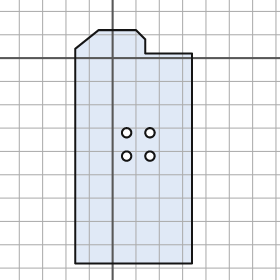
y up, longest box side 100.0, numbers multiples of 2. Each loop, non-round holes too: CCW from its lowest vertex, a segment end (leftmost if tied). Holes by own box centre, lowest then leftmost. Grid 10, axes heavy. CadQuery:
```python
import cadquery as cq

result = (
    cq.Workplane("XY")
    .moveTo(-16.0, -88.0)
    .lineTo(34.0, -88.0)
    .lineTo(34.0, 2.0)
    .lineTo(14.0, 2.0)
    .lineTo(14.0, 8.0)
    .lineTo(10.0, 12.0)
    .lineTo(-6.0, 12.0)
    .lineTo(-16.0, 4.0)
    .close()
    .moveTo(6.0, -42.0)
    .circle(2.0)
    .moveTo(16.0, -42.0)
    .circle(2.0)
    .moveTo(6.0, -32.0)
    .circle(2.0)
    .moveTo(16.0, -32.0)
    .circle(2.0)
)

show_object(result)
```